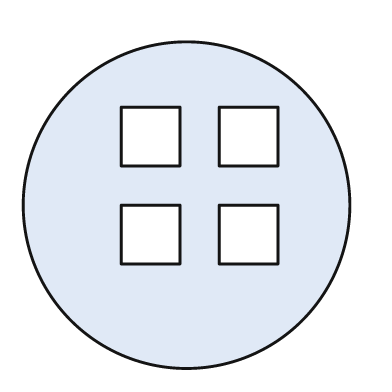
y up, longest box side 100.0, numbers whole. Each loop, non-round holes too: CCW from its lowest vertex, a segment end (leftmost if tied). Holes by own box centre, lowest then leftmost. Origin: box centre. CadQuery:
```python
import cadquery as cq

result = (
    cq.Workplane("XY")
    .moveTo(0.0, 0.0)
    .circle(50.0)
    .moveTo(-20.0, -18.0)
    .lineTo(-2.0, -18.0)
    .lineTo(-2.0, 0.0)
    .lineTo(-20.0, 0.0)
    .close()
    .moveTo(10.0, -18.0)
    .lineTo(28.0, -18.0)
    .lineTo(28.0, 0.0)
    .lineTo(10.0, 0.0)
    .close()
    .moveTo(-20.0, 12.0)
    .lineTo(-2.0, 12.0)
    .lineTo(-2.0, 30.0)
    .lineTo(-20.0, 30.0)
    .close()
    .moveTo(10.0, 12.0)
    .lineTo(28.0, 12.0)
    .lineTo(28.0, 30.0)
    .lineTo(10.0, 30.0)
    .close()
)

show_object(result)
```